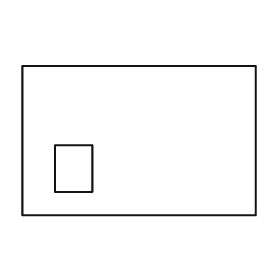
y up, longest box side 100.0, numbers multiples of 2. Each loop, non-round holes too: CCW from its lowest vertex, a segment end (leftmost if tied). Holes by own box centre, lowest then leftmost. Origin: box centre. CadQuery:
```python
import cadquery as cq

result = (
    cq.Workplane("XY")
    .moveTo(-50.0, -32.0)
    .lineTo(50.0, -32.0)
    .lineTo(50.0, 32.0)
    .lineTo(-50.0, 32.0)
    .close()
    .moveTo(-36.0, -22.0)
    .lineTo(-20.0, -22.0)
    .lineTo(-20.0, -2.0)
    .lineTo(-36.0, -2.0)
    .close()
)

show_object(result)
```